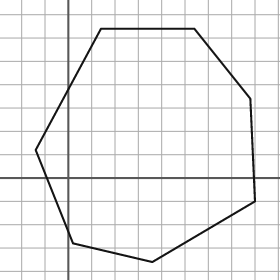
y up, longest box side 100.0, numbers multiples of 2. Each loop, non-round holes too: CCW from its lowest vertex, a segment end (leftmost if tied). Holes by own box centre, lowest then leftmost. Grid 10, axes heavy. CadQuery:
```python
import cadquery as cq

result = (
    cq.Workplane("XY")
    .moveTo(36.0, -36.0)
    .lineTo(80.0, -10.0)
    .lineTo(78.0, 34.0)
    .lineTo(54.0, 64.0)
    .lineTo(14.0, 64.0)
    .lineTo(-14.0, 12.0)
    .lineTo(2.0, -28.0)
    .close()
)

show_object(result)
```